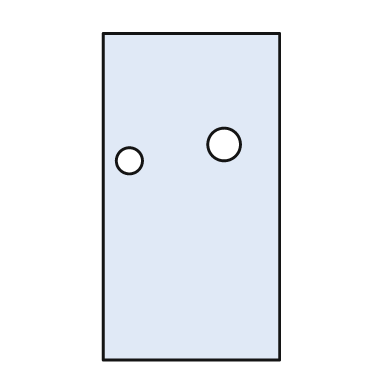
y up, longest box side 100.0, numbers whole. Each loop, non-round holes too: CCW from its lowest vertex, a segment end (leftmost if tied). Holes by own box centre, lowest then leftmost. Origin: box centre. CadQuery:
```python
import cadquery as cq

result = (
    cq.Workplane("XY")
    .moveTo(-27.0, -50.0)
    .lineTo(27.0, -50.0)
    .lineTo(27.0, 50.0)
    .lineTo(-27.0, 50.0)
    .close()
    .moveTo(-19.0, 11.0)
    .circle(4.0)
    .moveTo(10.0, 16.0)
    .circle(5.0)
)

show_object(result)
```